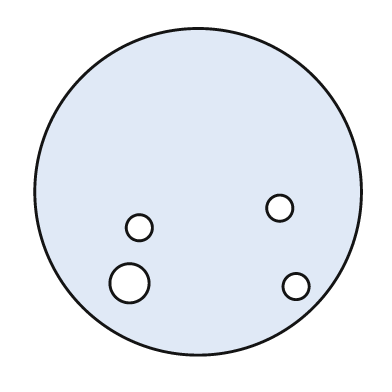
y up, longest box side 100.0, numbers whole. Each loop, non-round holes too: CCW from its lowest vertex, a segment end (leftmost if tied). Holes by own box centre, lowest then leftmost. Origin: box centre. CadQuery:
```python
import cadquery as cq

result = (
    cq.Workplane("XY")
    .moveTo(0.0, 0.0)
    .circle(50.0)
    .moveTo(30.0, -29.0)
    .circle(4.0)
    .moveTo(-21.0, -28.0)
    .circle(6.0)
    .moveTo(-18.0, -11.0)
    .circle(4.0)
    .moveTo(25.0, -5.0)
    .circle(4.0)
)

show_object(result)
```